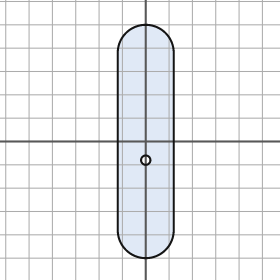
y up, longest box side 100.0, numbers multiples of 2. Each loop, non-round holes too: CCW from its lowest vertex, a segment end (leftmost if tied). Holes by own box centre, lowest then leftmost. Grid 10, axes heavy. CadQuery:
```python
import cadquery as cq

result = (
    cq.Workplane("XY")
    .moveTo(-12.0, -38.0)
    .threePointArc((0.0, -50.0), (12.0, -38.0))
    .lineTo(12.0, 38.0)
    .threePointArc((0.0, 50.0), (-12.0, 38.0))
    .close()
    .moveTo(0.0, -8.0)
    .circle(2.0)
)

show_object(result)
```